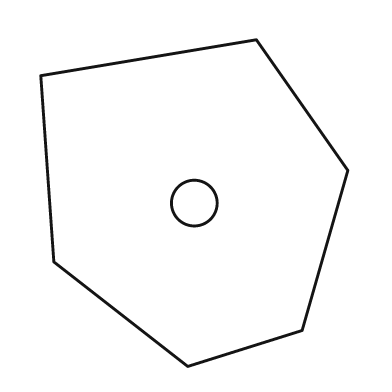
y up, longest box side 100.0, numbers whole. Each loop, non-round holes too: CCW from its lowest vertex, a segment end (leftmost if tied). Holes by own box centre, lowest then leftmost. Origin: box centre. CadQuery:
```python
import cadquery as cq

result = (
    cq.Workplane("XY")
    .moveTo(-2.0, -50.0)
    .lineTo(33.0, -39.0)
    .lineTo(47.0, 10.0)
    .lineTo(19.0, 50.0)
    .lineTo(-47.0, 39.0)
    .lineTo(-43.0, -18.0)
    .close()
    .moveTo(0.0, 0.0)
    .circle(7.0)
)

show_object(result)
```